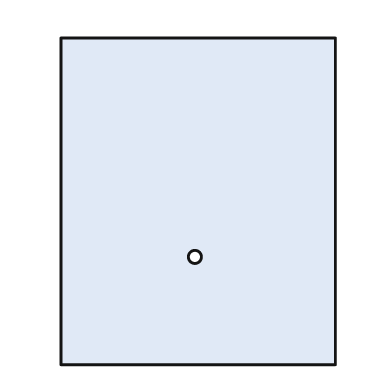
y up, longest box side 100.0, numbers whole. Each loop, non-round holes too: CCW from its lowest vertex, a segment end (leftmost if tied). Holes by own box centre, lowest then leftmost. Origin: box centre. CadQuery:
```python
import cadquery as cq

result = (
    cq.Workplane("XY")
    .moveTo(-42.0, -50.0)
    .lineTo(42.0, -50.0)
    .lineTo(42.0, 50.0)
    .lineTo(-42.0, 50.0)
    .close()
    .moveTo(-1.0, -17.0)
    .circle(2.0)
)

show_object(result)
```